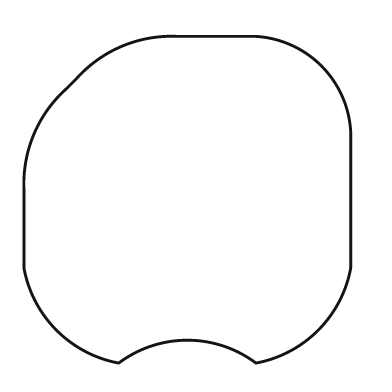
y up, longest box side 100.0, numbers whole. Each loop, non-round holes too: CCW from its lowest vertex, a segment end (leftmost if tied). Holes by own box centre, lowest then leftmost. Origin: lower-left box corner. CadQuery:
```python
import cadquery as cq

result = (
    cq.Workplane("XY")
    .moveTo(29.0, 0.0)
    .threePointArc((50.0, 7.0), (71.0, 0.0))
    .threePointArc((90.0, 10.0), (100.0, 29.0))
    .lineTo(100.0, 71.0)
    .threePointArc((91.0, 91.0), (71.0, 100.0))
    .lineTo(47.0, 100.0)
    .threePointArc((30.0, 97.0), (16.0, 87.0))
    .lineTo(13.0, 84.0)
    .threePointArc((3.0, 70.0), (0.0, 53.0))
    .lineTo(0.0, 29.0)
    .threePointArc((10.0, 10.0), (29.0, 0.0))
    .close()
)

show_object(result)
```